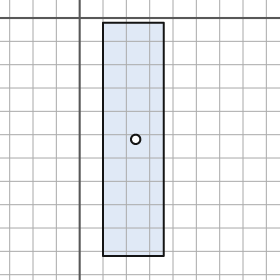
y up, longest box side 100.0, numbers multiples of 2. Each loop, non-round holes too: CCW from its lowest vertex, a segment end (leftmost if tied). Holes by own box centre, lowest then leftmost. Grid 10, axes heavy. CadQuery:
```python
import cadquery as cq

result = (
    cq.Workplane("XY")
    .moveTo(10.0, -102.0)
    .lineTo(36.0, -102.0)
    .lineTo(36.0, -2.0)
    .lineTo(10.0, -2.0)
    .close()
    .moveTo(24.0, -52.0)
    .circle(2.0)
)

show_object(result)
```